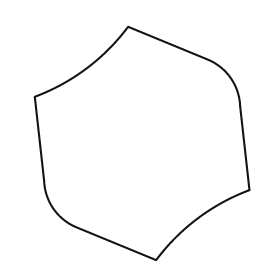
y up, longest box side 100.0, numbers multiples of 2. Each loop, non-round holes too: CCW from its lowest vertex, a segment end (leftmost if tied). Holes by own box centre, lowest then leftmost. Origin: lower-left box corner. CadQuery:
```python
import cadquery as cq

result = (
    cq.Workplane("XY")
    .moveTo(52.0, 0.0)
    .threePointArc((70.0, 18.0), (92.0, 30.0))
    .lineTo(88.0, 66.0)
    .threePointArc((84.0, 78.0), (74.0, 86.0))
    .lineTo(40.0, 100.0)
    .threePointArc((22.0, 82.0), (0.0, 70.0))
    .lineTo(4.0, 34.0)
    .threePointArc((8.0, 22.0), (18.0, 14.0))
    .close()
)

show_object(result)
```